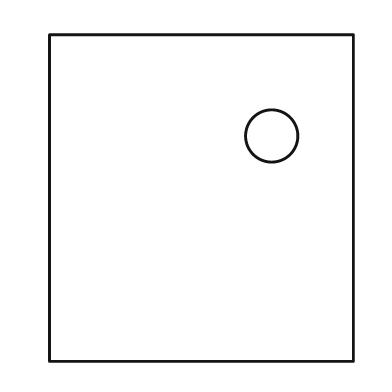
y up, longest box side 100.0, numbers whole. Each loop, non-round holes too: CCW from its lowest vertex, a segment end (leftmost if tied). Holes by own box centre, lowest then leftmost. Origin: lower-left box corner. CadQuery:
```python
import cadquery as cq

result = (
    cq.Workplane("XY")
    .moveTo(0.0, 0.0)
    .lineTo(93.0, 0.0)
    .lineTo(93.0, 100.0)
    .lineTo(0.0, 100.0)
    .close()
    .moveTo(68.0, 69.0)
    .circle(8.0)
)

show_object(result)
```